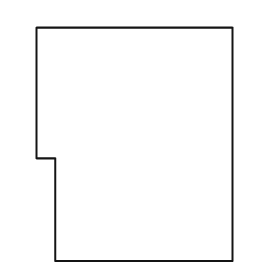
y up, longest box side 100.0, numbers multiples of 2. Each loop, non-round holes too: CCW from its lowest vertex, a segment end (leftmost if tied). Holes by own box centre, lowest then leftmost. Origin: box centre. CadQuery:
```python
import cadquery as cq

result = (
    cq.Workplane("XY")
    .moveTo(-34.0, -50.0)
    .lineTo(42.0, -50.0)
    .lineTo(42.0, 50.0)
    .lineTo(-42.0, 50.0)
    .lineTo(-42.0, -6.0)
    .lineTo(-34.0, -6.0)
    .close()
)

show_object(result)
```